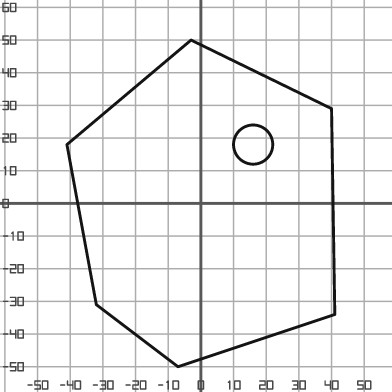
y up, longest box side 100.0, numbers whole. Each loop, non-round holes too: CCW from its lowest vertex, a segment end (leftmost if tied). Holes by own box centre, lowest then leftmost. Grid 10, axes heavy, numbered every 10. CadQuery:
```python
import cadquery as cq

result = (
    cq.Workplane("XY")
    .moveTo(-7.0, -50.0)
    .lineTo(41.0, -34.0)
    .lineTo(40.0, 29.0)
    .lineTo(-3.0, 50.0)
    .lineTo(-41.0, 18.0)
    .lineTo(-32.0, -31.0)
    .close()
    .moveTo(16.0, 18.0)
    .circle(6.0)
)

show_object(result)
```